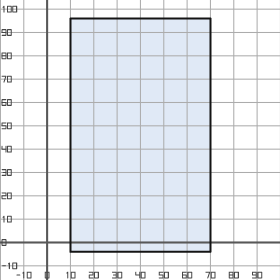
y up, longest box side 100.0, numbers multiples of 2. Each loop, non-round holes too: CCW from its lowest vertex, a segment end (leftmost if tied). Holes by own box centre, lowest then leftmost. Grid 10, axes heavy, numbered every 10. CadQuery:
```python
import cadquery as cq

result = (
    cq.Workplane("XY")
    .moveTo(10.0, -4.0)
    .lineTo(70.0, -4.0)
    .lineTo(70.0, 96.0)
    .lineTo(10.0, 96.0)
    .close()
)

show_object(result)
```